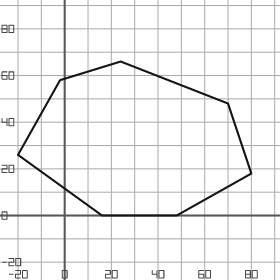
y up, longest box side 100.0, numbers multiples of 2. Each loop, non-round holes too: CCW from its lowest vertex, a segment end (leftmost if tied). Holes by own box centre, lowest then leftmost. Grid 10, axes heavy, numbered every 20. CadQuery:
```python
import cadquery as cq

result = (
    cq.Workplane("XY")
    .moveTo(16.0, 0.0)
    .lineTo(48.0, 0.0)
    .lineTo(80.0, 18.0)
    .lineTo(70.0, 48.0)
    .lineTo(24.0, 66.0)
    .lineTo(-2.0, 58.0)
    .lineTo(-20.0, 26.0)
    .close()
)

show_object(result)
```